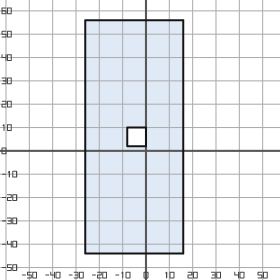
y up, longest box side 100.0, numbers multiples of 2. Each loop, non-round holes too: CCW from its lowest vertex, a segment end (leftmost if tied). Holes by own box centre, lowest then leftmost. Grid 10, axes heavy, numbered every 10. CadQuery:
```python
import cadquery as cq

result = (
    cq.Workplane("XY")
    .moveTo(-26.0, -44.0)
    .lineTo(16.0, -44.0)
    .lineTo(16.0, 56.0)
    .lineTo(-26.0, 56.0)
    .close()
    .moveTo(-8.0, 2.0)
    .lineTo(0.0, 2.0)
    .lineTo(0.0, 10.0)
    .lineTo(-8.0, 10.0)
    .close()
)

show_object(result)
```